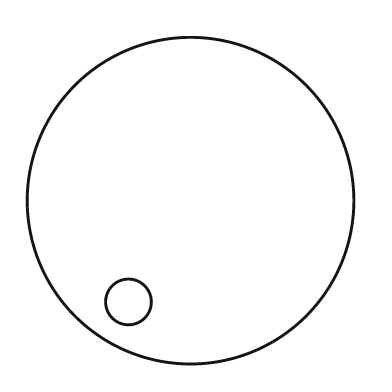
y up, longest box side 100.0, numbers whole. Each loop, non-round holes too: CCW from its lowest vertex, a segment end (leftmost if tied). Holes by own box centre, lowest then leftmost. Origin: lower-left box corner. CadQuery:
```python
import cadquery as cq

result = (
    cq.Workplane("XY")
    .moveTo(50.0, 50.0)
    .circle(50.0)
    .moveTo(31.0, 19.0)
    .circle(7.0)
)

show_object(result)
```